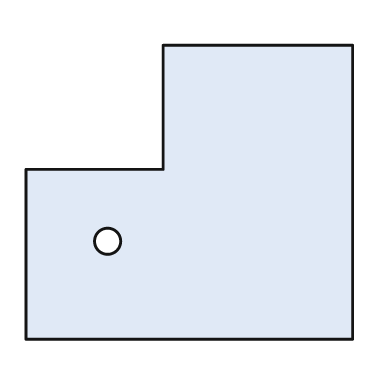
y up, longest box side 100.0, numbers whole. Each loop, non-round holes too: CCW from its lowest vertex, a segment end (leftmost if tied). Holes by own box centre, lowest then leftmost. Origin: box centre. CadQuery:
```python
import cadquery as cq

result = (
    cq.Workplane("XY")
    .moveTo(-50.0, -45.0)
    .lineTo(50.0, -45.0)
    .lineTo(50.0, 45.0)
    .lineTo(-8.0, 45.0)
    .lineTo(-8.0, 7.0)
    .lineTo(-50.0, 7.0)
    .close()
    .moveTo(-25.0, -15.0)
    .circle(4.0)
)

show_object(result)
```